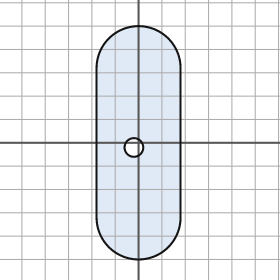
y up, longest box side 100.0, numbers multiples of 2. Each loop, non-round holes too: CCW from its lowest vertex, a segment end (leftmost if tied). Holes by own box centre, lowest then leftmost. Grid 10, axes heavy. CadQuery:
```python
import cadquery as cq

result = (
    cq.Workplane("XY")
    .moveTo(-18.0, -32.0)
    .threePointArc((0.0, -50.0), (18.0, -32.0))
    .lineTo(18.0, 32.0)
    .threePointArc((0.0, 50.0), (-18.0, 32.0))
    .close()
    .moveTo(-2.0, -2.0)
    .circle(4.0)
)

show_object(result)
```